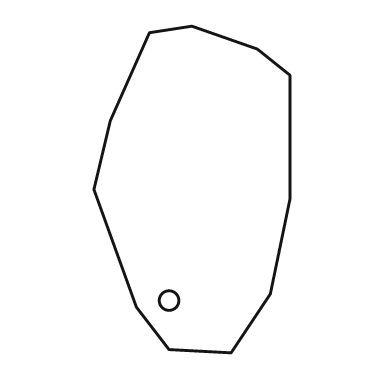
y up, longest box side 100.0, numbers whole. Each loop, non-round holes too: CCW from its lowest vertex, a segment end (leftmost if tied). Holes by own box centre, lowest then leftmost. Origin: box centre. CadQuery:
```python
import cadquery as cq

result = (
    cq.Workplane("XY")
    .moveTo(12.0, -50.0)
    .lineTo(24.0, -32.0)
    .lineTo(30.0, -3.0)
    .lineTo(30.0, 35.0)
    .lineTo(20.0, 43.0)
    .lineTo(0.0, 50.0)
    .lineTo(-13.0, 48.0)
    .lineTo(-25.0, 21.0)
    .lineTo(-30.0, 0.0)
    .lineTo(-17.0, -36.0)
    .lineTo(-7.0, -49.0)
    .close()
    .moveTo(-7.0, -34.0)
    .circle(3.0)
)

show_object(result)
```